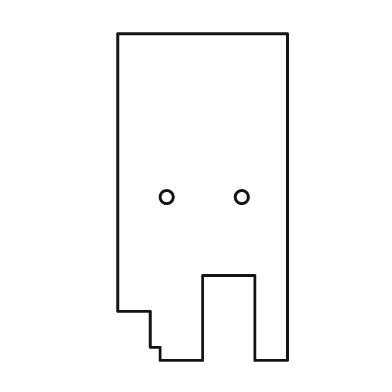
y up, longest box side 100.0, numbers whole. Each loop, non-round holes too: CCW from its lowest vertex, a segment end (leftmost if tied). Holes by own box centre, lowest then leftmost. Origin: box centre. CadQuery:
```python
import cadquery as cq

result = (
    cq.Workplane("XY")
    .moveTo(-13.0, -50.0)
    .lineTo(0.0, -50.0)
    .lineTo(0.0, -24.0)
    .lineTo(16.0, -24.0)
    .lineTo(16.0, -50.0)
    .lineTo(26.0, -50.0)
    .lineTo(26.0, 50.0)
    .lineTo(-26.0, 50.0)
    .lineTo(-26.0, -35.0)
    .lineTo(-16.0, -35.0)
    .lineTo(-16.0, -46.0)
    .lineTo(-13.0, -46.0)
    .close()
    .moveTo(-11.0, 0.0)
    .circle(2.0)
    .moveTo(12.0, 0.0)
    .circle(2.0)
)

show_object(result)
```